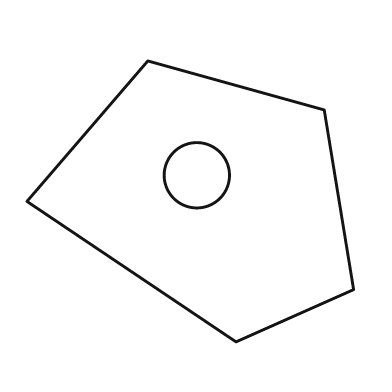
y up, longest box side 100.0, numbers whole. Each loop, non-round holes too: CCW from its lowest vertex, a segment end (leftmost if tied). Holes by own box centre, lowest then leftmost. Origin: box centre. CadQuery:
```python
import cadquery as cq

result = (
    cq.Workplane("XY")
    .moveTo(14.0, -43.0)
    .lineTo(50.0, -27.0)
    .lineTo(41.0, 28.0)
    .lineTo(-13.0, 43.0)
    .lineTo(-50.0, 0.0)
    .close()
    .moveTo(2.0, 8.0)
    .circle(10.0)
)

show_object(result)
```